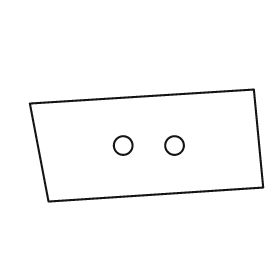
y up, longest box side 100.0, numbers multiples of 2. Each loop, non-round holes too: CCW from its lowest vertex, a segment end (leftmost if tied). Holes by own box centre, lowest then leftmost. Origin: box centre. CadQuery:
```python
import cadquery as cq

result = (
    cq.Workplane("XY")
    .moveTo(-42.0, -24.0)
    .lineTo(50.0, -18.0)
    .lineTo(46.0, 24.0)
    .lineTo(-50.0, 18.0)
    .close()
    .moveTo(-10.0, 0.0)
    .circle(4.0)
    .moveTo(12.0, 0.0)
    .circle(4.0)
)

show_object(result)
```